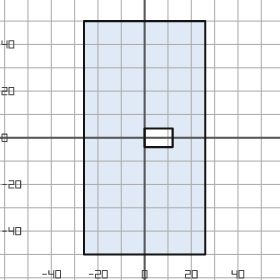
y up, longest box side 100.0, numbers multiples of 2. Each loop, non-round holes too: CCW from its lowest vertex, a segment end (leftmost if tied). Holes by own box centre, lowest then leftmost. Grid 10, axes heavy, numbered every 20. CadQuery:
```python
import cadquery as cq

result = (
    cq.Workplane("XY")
    .moveTo(-26.0, -50.0)
    .lineTo(26.0, -50.0)
    .lineTo(26.0, 50.0)
    .lineTo(-26.0, 50.0)
    .close()
    .moveTo(0.0, -4.0)
    .lineTo(12.0, -4.0)
    .lineTo(12.0, 4.0)
    .lineTo(0.0, 4.0)
    .close()
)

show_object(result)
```